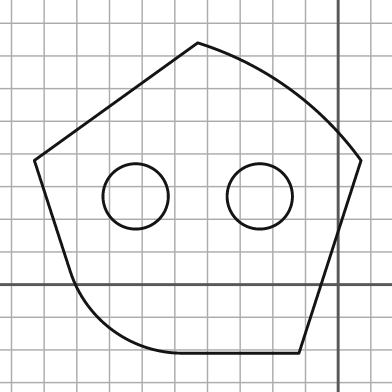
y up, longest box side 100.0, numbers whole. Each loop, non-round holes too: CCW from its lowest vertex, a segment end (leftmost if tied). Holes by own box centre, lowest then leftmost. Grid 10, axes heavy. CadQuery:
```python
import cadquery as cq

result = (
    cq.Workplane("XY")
    .moveTo(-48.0, -21.0)
    .lineTo(-12.0, -21.0)
    .lineTo(7.0, 38.0)
    .threePointArc((-15.0, 60.0), (-43.0, 74.0))
    .lineTo(-93.0, 38.0)
    .lineTo(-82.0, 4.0)
    .threePointArc((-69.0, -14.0), (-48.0, -21.0))
    .close()
    .moveTo(-62.0, 27.0)
    .circle(10.0)
    .moveTo(-24.0, 27.0)
    .circle(10.0)
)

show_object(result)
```